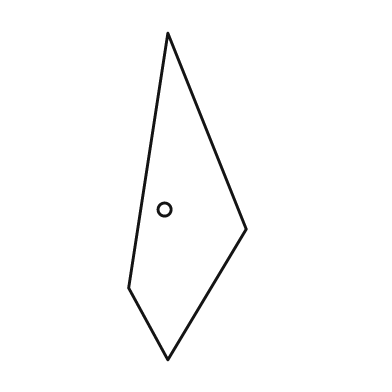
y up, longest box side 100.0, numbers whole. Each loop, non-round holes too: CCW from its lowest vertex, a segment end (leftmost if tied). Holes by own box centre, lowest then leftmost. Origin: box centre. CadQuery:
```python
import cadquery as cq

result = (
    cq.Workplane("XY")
    .moveTo(-6.0, -50.0)
    .lineTo(18.0, -10.0)
    .lineTo(-6.0, 50.0)
    .lineTo(-18.0, -28.0)
    .close()
    .moveTo(-7.0, -4.0)
    .circle(2.0)
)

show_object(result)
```